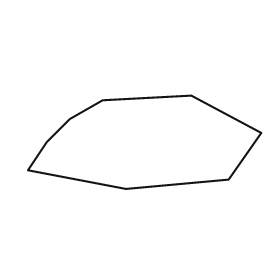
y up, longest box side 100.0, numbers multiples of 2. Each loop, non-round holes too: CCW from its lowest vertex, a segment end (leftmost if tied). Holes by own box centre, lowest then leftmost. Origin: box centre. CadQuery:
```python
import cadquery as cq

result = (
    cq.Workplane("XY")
    .moveTo(-8.0, -20.0)
    .lineTo(36.0, -16.0)
    .lineTo(50.0, 4.0)
    .lineTo(20.0, 20.0)
    .lineTo(-18.0, 18.0)
    .lineTo(-32.0, 10.0)
    .lineTo(-42.0, 0.0)
    .lineTo(-50.0, -12.0)
    .close()
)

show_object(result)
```